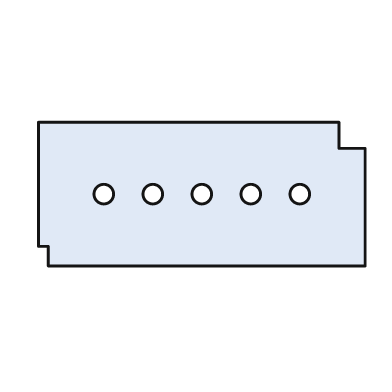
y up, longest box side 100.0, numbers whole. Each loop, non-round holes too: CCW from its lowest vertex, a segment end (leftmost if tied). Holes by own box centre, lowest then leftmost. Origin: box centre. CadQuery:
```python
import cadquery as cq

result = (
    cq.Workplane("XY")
    .moveTo(-47.0, -22.0)
    .lineTo(50.0, -22.0)
    .lineTo(50.0, 14.0)
    .lineTo(42.0, 14.0)
    .lineTo(42.0, 22.0)
    .lineTo(-50.0, 22.0)
    .lineTo(-50.0, -16.0)
    .lineTo(-47.0, -16.0)
    .close()
    .moveTo(-30.0, 0.0)
    .circle(3.0)
    .moveTo(-15.0, 0.0)
    .circle(3.0)
    .moveTo(0.0, 0.0)
    .circle(3.0)
    .moveTo(15.0, 0.0)
    .circle(3.0)
    .moveTo(30.0, 0.0)
    .circle(3.0)
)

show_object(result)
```